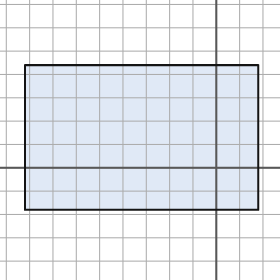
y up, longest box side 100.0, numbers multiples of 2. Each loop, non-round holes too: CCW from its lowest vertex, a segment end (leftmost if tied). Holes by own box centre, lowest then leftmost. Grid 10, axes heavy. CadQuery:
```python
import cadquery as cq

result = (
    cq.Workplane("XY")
    .moveTo(-82.0, -18.0)
    .lineTo(18.0, -18.0)
    .lineTo(18.0, 44.0)
    .lineTo(-82.0, 44.0)
    .close()
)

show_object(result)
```